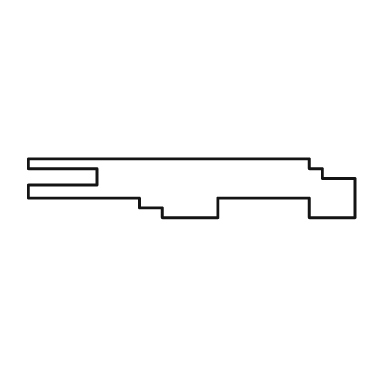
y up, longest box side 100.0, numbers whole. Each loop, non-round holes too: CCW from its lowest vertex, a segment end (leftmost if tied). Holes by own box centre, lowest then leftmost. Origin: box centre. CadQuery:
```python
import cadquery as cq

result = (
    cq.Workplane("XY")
    .moveTo(-9.0, -9.0)
    .lineTo(8.0, -9.0)
    .lineTo(8.0, -3.0)
    .lineTo(36.0, -3.0)
    .lineTo(36.0, -9.0)
    .lineTo(50.0, -9.0)
    .lineTo(50.0, 3.0)
    .lineTo(40.0, 3.0)
    .lineTo(40.0, 6.0)
    .lineTo(36.0, 6.0)
    .lineTo(36.0, 9.0)
    .lineTo(-50.0, 9.0)
    .lineTo(-50.0, 6.0)
    .lineTo(-29.0, 6.0)
    .lineTo(-29.0, 1.0)
    .lineTo(-50.0, 1.0)
    .lineTo(-50.0, -3.0)
    .lineTo(-16.0, -3.0)
    .lineTo(-16.0, -6.0)
    .lineTo(-9.0, -6.0)
    .close()
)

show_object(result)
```